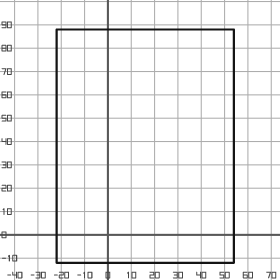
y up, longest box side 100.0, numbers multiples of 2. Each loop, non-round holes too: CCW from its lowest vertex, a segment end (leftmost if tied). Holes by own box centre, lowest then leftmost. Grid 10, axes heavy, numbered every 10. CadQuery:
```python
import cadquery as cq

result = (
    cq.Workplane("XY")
    .moveTo(-22.0, -12.0)
    .lineTo(54.0, -12.0)
    .lineTo(54.0, 88.0)
    .lineTo(-22.0, 88.0)
    .close()
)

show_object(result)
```